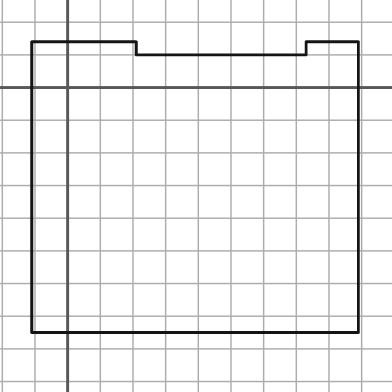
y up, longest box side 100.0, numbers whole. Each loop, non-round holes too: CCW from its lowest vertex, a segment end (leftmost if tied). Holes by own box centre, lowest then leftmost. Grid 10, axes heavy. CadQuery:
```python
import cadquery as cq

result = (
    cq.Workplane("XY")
    .moveTo(-11.0, -75.0)
    .lineTo(89.0, -75.0)
    .lineTo(89.0, 14.0)
    .lineTo(73.0, 14.0)
    .lineTo(73.0, 10.0)
    .lineTo(21.0, 10.0)
    .lineTo(21.0, 14.0)
    .lineTo(-11.0, 14.0)
    .close()
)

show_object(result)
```